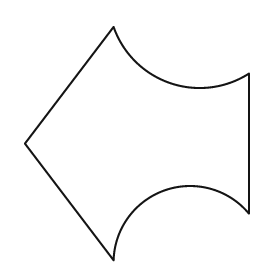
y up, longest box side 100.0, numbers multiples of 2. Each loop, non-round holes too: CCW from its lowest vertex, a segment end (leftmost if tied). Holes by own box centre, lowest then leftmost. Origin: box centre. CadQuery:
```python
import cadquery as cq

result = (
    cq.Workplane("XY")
    .moveTo(-10.0, -50.0)
    .threePointArc((12.0, -20.0), (48.0, -30.0))
    .lineTo(48.0, 30.0)
    .threePointArc((14.0, 26.0), (-10.0, 50.0))
    .lineTo(-48.0, 0.0)
    .close()
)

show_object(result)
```